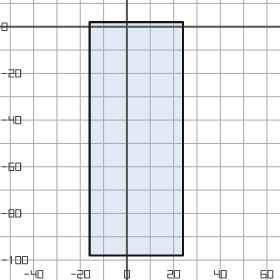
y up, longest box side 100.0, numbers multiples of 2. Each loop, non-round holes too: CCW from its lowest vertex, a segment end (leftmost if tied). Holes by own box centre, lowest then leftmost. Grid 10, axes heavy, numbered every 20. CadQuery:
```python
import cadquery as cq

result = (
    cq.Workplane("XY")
    .moveTo(-16.0, -98.0)
    .lineTo(24.0, -98.0)
    .lineTo(24.0, 2.0)
    .lineTo(-16.0, 2.0)
    .close()
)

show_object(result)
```